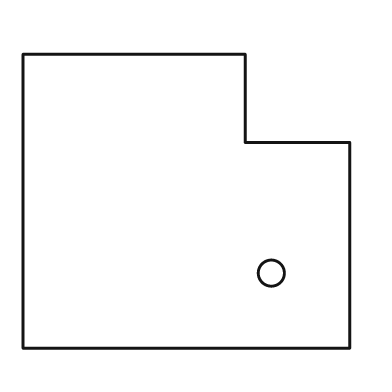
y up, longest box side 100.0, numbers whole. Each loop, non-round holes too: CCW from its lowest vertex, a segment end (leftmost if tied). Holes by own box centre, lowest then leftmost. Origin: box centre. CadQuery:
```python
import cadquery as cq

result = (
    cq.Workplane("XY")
    .moveTo(-50.0, -45.0)
    .lineTo(50.0, -45.0)
    .lineTo(50.0, 18.0)
    .lineTo(18.0, 18.0)
    .lineTo(18.0, 45.0)
    .lineTo(-50.0, 45.0)
    .close()
    .moveTo(26.0, -22.0)
    .circle(4.0)
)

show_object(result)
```